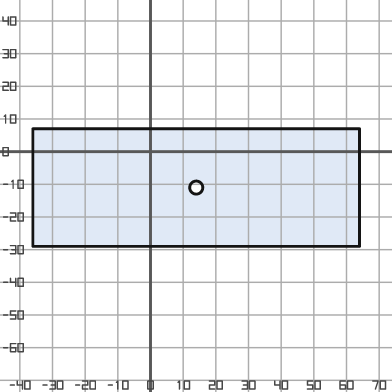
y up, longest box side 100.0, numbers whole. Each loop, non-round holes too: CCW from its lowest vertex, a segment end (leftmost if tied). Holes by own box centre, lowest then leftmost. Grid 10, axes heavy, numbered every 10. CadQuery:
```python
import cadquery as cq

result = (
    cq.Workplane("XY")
    .moveTo(-36.0, -29.0)
    .lineTo(64.0, -29.0)
    .lineTo(64.0, 7.0)
    .lineTo(-36.0, 7.0)
    .close()
    .moveTo(14.0, -11.0)
    .circle(2.0)
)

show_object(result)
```